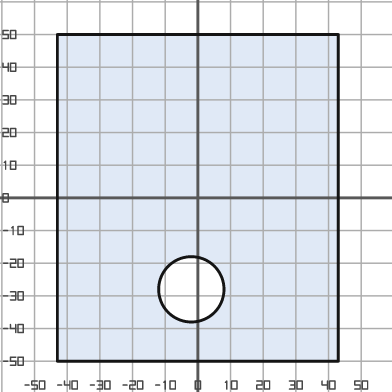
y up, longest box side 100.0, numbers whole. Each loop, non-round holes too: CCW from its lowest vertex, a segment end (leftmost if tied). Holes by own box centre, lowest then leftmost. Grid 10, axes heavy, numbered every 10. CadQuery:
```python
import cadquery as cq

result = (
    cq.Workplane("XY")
    .moveTo(-43.0, -50.0)
    .lineTo(43.0, -50.0)
    .lineTo(43.0, 50.0)
    .lineTo(-43.0, 50.0)
    .close()
    .moveTo(-2.0, -28.0)
    .circle(10.0)
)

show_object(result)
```